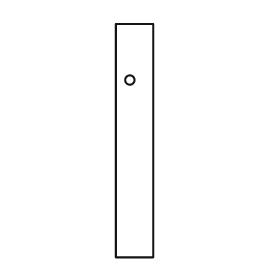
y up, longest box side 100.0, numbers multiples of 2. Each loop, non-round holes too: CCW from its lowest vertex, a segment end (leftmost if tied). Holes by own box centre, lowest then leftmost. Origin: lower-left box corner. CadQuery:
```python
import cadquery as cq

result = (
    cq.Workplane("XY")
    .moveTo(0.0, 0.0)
    .lineTo(16.0, 0.0)
    .lineTo(16.0, 100.0)
    .lineTo(0.0, 100.0)
    .close()
    .moveTo(6.0, 76.0)
    .circle(2.0)
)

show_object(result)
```